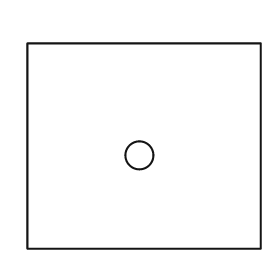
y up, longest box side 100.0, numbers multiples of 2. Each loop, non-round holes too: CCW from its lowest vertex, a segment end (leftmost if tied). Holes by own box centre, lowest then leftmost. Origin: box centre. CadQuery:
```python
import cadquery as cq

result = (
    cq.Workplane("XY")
    .moveTo(-50.0, -44.0)
    .lineTo(50.0, -44.0)
    .lineTo(50.0, 44.0)
    .lineTo(-50.0, 44.0)
    .close()
    .moveTo(-2.0, -4.0)
    .circle(6.0)
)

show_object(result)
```